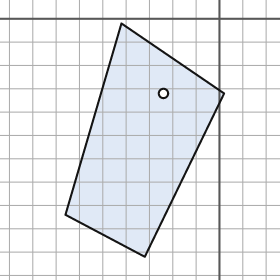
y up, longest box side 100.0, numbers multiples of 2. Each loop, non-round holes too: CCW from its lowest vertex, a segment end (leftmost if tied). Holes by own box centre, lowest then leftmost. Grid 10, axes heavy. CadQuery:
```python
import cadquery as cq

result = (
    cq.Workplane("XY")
    .moveTo(-32.0, -102.0)
    .lineTo(2.0, -32.0)
    .lineTo(-42.0, -2.0)
    .lineTo(-66.0, -84.0)
    .close()
    .moveTo(-24.0, -32.0)
    .circle(2.0)
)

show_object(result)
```